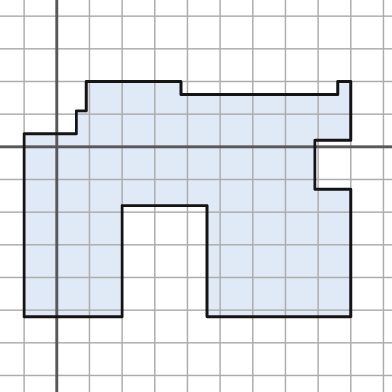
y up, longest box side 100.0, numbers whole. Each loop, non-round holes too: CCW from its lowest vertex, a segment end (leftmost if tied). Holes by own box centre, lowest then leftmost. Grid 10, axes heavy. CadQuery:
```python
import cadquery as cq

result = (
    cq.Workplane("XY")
    .moveTo(-10.0, -52.0)
    .lineTo(20.0, -52.0)
    .lineTo(20.0, -18.0)
    .lineTo(46.0, -18.0)
    .lineTo(46.0, -52.0)
    .lineTo(90.0, -52.0)
    .lineTo(90.0, -13.0)
    .lineTo(79.0, -13.0)
    .lineTo(79.0, 2.0)
    .lineTo(90.0, 2.0)
    .lineTo(90.0, 20.0)
    .lineTo(86.0, 20.0)
    .lineTo(86.0, 16.0)
    .lineTo(38.0, 16.0)
    .lineTo(38.0, 20.0)
    .lineTo(9.0, 20.0)
    .lineTo(9.0, 11.0)
    .lineTo(6.0, 11.0)
    .lineTo(6.0, 4.0)
    .lineTo(-10.0, 4.0)
    .close()
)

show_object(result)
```